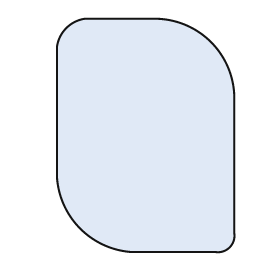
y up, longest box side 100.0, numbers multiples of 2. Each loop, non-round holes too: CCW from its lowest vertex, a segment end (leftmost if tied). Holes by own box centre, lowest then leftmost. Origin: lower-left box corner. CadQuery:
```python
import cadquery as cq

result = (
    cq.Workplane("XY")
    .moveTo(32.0, 0.0)
    .lineTo(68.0, 0.0)
    .threePointArc((74.0, 2.0), (76.0, 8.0))
    .lineTo(76.0, 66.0)
    .threePointArc((66.0, 90.0), (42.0, 100.0))
    .lineTo(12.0, 100.0)
    .threePointArc((4.0, 96.0), (0.0, 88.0))
    .lineTo(0.0, 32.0)
    .threePointArc((10.0, 10.0), (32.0, 0.0))
    .close()
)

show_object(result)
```